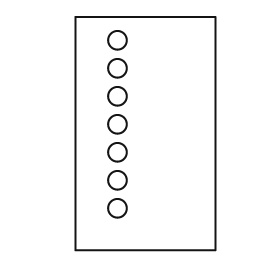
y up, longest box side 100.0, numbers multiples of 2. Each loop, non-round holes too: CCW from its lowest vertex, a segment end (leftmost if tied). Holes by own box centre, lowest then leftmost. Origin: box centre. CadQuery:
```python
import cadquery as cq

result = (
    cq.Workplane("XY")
    .moveTo(-30.0, -50.0)
    .lineTo(30.0, -50.0)
    .lineTo(30.0, 50.0)
    .lineTo(-30.0, 50.0)
    .close()
    .moveTo(-12.0, -32.0)
    .circle(4.0)
    .moveTo(-12.0, -20.0)
    .circle(4.0)
    .moveTo(-12.0, -8.0)
    .circle(4.0)
    .moveTo(-12.0, 4.0)
    .circle(4.0)
    .moveTo(-12.0, 16.0)
    .circle(4.0)
    .moveTo(-12.0, 28.0)
    .circle(4.0)
    .moveTo(-12.0, 40.0)
    .circle(4.0)
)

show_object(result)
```